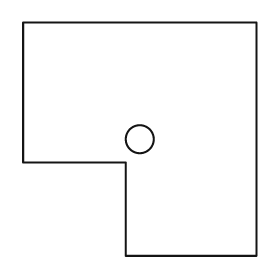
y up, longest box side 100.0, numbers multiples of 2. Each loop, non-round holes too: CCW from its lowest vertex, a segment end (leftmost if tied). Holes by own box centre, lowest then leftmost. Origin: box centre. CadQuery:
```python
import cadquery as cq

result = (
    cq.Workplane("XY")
    .moveTo(-6.0, -50.0)
    .lineTo(50.0, -50.0)
    .lineTo(50.0, 50.0)
    .lineTo(-50.0, 50.0)
    .lineTo(-50.0, -10.0)
    .lineTo(-6.0, -10.0)
    .close()
    .moveTo(0.0, 0.0)
    .circle(6.0)
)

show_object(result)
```